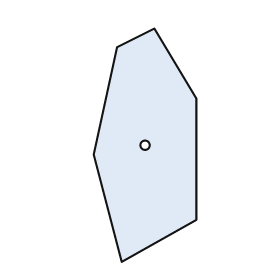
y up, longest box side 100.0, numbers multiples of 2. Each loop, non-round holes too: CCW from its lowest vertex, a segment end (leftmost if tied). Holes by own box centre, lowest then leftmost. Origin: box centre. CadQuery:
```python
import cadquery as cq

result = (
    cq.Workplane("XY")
    .moveTo(-10.0, -50.0)
    .lineTo(22.0, -32.0)
    .lineTo(22.0, 20.0)
    .lineTo(4.0, 50.0)
    .lineTo(-12.0, 42.0)
    .lineTo(-22.0, -4.0)
    .close()
    .moveTo(0.0, 0.0)
    .circle(2.0)
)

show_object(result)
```